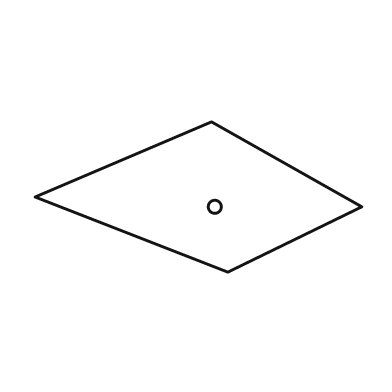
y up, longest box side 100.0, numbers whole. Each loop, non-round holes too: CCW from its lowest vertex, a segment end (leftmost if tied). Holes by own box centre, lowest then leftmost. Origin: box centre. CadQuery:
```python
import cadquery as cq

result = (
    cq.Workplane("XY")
    .moveTo(9.0, -23.0)
    .lineTo(50.0, -3.0)
    .lineTo(4.0, 23.0)
    .lineTo(-50.0, 0.0)
    .close()
    .moveTo(5.0, -3.0)
    .circle(2.0)
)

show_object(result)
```